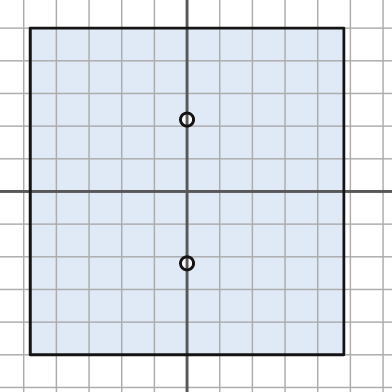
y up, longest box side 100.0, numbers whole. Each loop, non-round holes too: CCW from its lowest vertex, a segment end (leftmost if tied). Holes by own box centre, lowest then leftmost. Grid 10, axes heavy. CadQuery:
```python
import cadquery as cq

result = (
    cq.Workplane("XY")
    .moveTo(-48.0, -50.0)
    .lineTo(48.0, -50.0)
    .lineTo(48.0, 50.0)
    .lineTo(-48.0, 50.0)
    .close()
    .moveTo(0.0, -22.0)
    .circle(2.0)
    .moveTo(0.0, 22.0)
    .circle(2.0)
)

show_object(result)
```